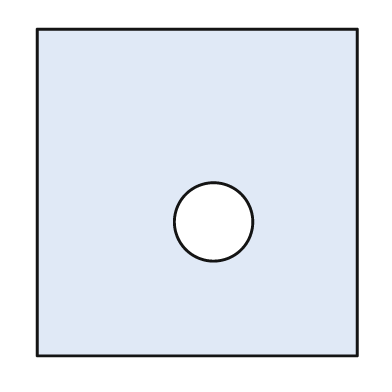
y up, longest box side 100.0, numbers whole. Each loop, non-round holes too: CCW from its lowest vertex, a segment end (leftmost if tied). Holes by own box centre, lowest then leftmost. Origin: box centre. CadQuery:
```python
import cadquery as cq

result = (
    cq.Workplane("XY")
    .moveTo(-49.0, -50.0)
    .lineTo(49.0, -50.0)
    .lineTo(49.0, 50.0)
    .lineTo(-49.0, 50.0)
    .close()
    .moveTo(5.0, -9.0)
    .circle(12.0)
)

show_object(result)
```